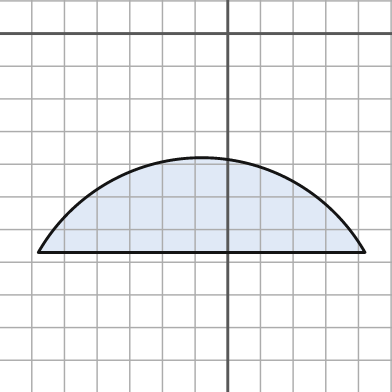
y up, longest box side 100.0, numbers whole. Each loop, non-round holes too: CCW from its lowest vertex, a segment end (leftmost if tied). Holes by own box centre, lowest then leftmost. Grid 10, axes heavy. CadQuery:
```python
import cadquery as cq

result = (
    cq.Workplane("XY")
    .moveTo(-58.0, -67.0)
    .lineTo(42.0, -67.0)
    .threePointArc((-8.0, -38.0), (-58.0, -67.0))
    .close()
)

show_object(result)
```